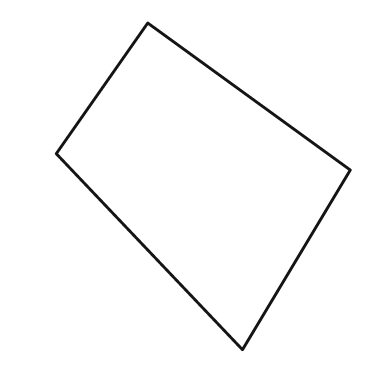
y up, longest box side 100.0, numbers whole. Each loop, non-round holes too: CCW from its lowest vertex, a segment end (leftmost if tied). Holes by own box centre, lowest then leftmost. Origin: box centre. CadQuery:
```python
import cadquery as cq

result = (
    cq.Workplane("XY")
    .moveTo(12.0, -50.0)
    .lineTo(45.0, 5.0)
    .lineTo(-17.0, 50.0)
    .lineTo(-45.0, 10.0)
    .close()
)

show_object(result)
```